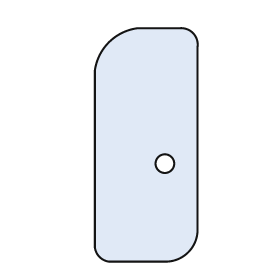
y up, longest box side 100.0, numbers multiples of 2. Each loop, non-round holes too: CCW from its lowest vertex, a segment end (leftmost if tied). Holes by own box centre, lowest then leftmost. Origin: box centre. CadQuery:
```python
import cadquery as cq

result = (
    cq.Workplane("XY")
    .moveTo(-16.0, -50.0)
    .lineTo(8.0, -50.0)
    .threePointArc((18.0, -46.0), (22.0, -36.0))
    .lineTo(22.0, 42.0)
    .threePointArc((20.0, 48.0), (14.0, 50.0))
    .lineTo(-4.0, 50.0)
    .threePointArc((-16.0, 44.0), (-22.0, 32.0))
    .lineTo(-22.0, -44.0)
    .threePointArc((-20.0, -48.0), (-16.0, -50.0))
    .close()
    .moveTo(8.0, -8.0)
    .circle(4.0)
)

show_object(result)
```